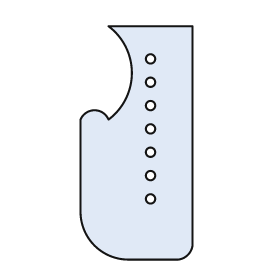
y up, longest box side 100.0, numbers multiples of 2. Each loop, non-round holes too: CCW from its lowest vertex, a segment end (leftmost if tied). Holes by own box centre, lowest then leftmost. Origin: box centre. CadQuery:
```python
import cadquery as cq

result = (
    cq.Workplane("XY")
    .moveTo(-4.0, -50.0)
    .lineTo(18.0, -50.0)
    .threePointArc((22.0, -48.0), (24.0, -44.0))
    .lineTo(24.0, 50.0)
    .lineTo(-12.0, 50.0)
    .threePointArc((-2.0, 30.0), (-12.0, 10.0))
    .threePointArc((-18.0, 14.0), (-24.0, 10.0))
    .lineTo(-24.0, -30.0)
    .threePointArc((-18.0, -44.0), (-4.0, -50.0))
    .close()
    .moveTo(6.0, -24.0)
    .circle(2.0)
    .moveTo(6.0, -14.0)
    .circle(2.0)
    .moveTo(6.0, -4.0)
    .circle(2.0)
    .moveTo(6.0, 6.0)
    .circle(2.0)
    .moveTo(6.0, 16.0)
    .circle(2.0)
    .moveTo(6.0, 26.0)
    .circle(2.0)
    .moveTo(6.0, 36.0)
    .circle(2.0)
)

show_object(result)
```